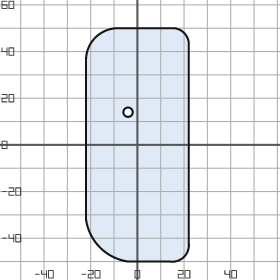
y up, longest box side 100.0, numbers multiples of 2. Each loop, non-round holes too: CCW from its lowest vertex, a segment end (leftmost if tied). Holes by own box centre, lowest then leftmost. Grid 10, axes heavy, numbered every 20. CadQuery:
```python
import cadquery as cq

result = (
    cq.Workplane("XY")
    .moveTo(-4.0, -50.0)
    .lineTo(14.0, -50.0)
    .threePointArc((20.0, -48.0), (22.0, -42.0))
    .lineTo(22.0, 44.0)
    .threePointArc((20.0, 48.0), (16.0, 50.0))
    .lineTo(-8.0, 50.0)
    .threePointArc((-18.0, 46.0), (-22.0, 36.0))
    .lineTo(-22.0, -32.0)
    .threePointArc((-16.0, -44.0), (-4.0, -50.0))
    .close()
    .moveTo(-4.0, 14.0)
    .circle(2.0)
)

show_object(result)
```